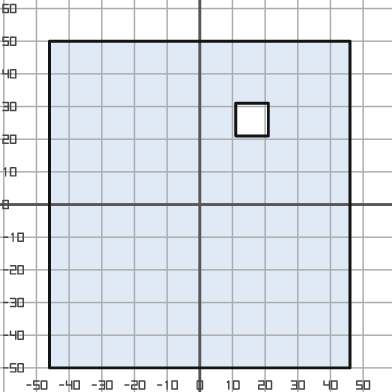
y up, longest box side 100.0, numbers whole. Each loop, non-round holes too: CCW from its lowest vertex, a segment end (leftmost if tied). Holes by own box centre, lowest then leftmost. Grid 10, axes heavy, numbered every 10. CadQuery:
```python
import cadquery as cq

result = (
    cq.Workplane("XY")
    .moveTo(-46.0, -50.0)
    .lineTo(46.0, -50.0)
    .lineTo(46.0, 50.0)
    .lineTo(-46.0, 50.0)
    .close()
    .moveTo(11.0, 21.0)
    .lineTo(21.0, 21.0)
    .lineTo(21.0, 31.0)
    .lineTo(11.0, 31.0)
    .close()
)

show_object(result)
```